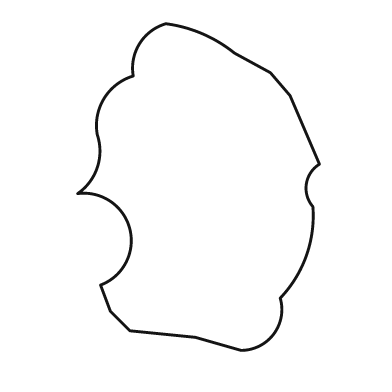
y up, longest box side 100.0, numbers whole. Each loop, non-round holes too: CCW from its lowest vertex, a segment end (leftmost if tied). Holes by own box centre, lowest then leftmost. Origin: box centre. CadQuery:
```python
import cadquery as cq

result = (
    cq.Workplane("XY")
    .moveTo(13.0, -50.0)
    .threePointArc((23.0, -45.0), (25.0, -34.0))
    .threePointArc((33.0, -21.0), (35.0, -6.0))
    .threePointArc((33.0, 1.0), (37.0, 7.0))
    .lineTo(28.0, 28.0)
    .lineTo(22.0, 35.0)
    .lineTo(11.0, 41.0)
    .threePointArc((1.0, 47.0), (-10.0, 50.0))
    .threePointArc((-18.0, 44.0), (-20.0, 34.0))
    .threePointArc((-29.0, 27.0), (-31.0, 16.0))
    .threePointArc((-31.0, 6.0), (-37.0, -2.0))
    .threePointArc((-21.0, -13.0), (-30.0, -30.0))
    .lineTo(-27.0, -38.0)
    .lineTo(-21.0, -44.0)
    .lineTo(-1.0, -46.0)
    .close()
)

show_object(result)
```